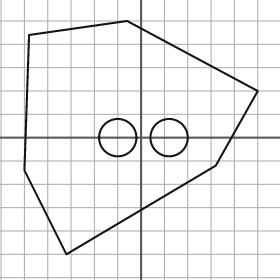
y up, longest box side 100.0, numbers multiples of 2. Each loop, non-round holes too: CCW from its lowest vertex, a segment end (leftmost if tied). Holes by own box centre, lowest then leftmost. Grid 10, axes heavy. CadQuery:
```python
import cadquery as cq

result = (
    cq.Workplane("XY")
    .moveTo(-32.0, -50.0)
    .lineTo(32.0, -12.0)
    .lineTo(50.0, 20.0)
    .lineTo(-6.0, 50.0)
    .lineTo(-48.0, 44.0)
    .lineTo(-50.0, -14.0)
    .close()
    .moveTo(-10.0, 0.0)
    .circle(8.0)
    .moveTo(12.0, 0.0)
    .circle(8.0)
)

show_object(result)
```